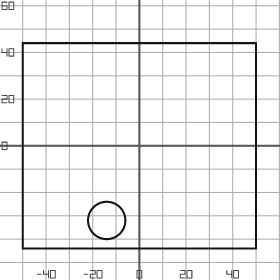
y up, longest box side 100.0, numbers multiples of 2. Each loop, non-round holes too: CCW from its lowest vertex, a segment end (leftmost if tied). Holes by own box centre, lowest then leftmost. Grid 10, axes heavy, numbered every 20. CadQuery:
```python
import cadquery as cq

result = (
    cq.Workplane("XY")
    .moveTo(-50.0, -44.0)
    .lineTo(50.0, -44.0)
    .lineTo(50.0, 44.0)
    .lineTo(-50.0, 44.0)
    .close()
    .moveTo(-14.0, -32.0)
    .circle(8.0)
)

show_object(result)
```